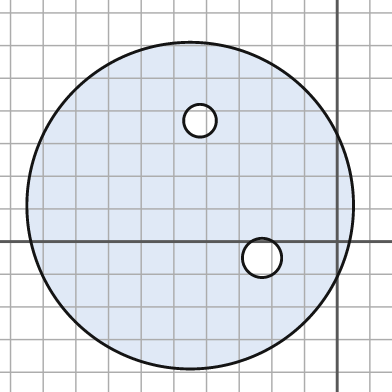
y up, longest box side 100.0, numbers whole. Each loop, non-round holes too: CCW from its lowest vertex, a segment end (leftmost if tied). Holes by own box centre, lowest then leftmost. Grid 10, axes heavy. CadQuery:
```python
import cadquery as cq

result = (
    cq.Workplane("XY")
    .moveTo(-45.0, 11.0)
    .circle(50.0)
    .moveTo(-23.0, -5.0)
    .circle(6.0)
    .moveTo(-42.0, 37.0)
    .circle(5.0)
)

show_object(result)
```